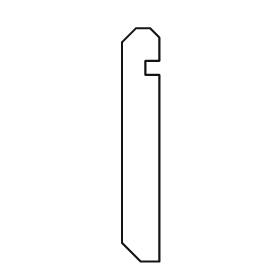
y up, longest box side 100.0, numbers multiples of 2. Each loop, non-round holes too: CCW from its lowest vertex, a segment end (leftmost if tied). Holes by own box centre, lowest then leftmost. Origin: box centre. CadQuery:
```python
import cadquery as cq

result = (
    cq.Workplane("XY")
    .moveTo(0.0, -50.0)
    .lineTo(8.0, -50.0)
    .lineTo(8.0, 30.0)
    .lineTo(2.0, 30.0)
    .lineTo(2.0, 36.0)
    .lineTo(8.0, 36.0)
    .lineTo(8.0, 46.0)
    .lineTo(4.0, 50.0)
    .lineTo(-2.0, 50.0)
    .lineTo(-8.0, 44.0)
    .lineTo(-8.0, -42.0)
    .close()
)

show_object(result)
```